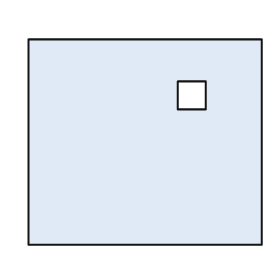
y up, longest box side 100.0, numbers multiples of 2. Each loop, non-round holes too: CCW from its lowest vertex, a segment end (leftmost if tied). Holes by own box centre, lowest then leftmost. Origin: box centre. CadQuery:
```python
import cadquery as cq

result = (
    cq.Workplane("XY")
    .moveTo(-50.0, -44.0)
    .lineTo(50.0, -44.0)
    .lineTo(50.0, 44.0)
    .lineTo(-50.0, 44.0)
    .close()
    .moveTo(14.0, 14.0)
    .lineTo(26.0, 14.0)
    .lineTo(26.0, 26.0)
    .lineTo(14.0, 26.0)
    .close()
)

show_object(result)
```